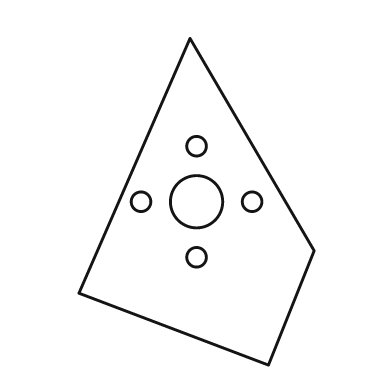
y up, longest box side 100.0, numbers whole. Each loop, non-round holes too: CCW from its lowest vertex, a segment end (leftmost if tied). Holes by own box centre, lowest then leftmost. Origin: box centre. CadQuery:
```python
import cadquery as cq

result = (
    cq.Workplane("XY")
    .moveTo(22.0, -50.0)
    .lineTo(36.0, -15.0)
    .lineTo(-2.0, 50.0)
    .lineTo(-36.0, -28.0)
    .close()
    .moveTo(0.0, -17.0)
    .circle(3.0)
    .moveTo(-17.0, 0.0)
    .circle(3.0)
    .moveTo(0.0, 0.0)
    .circle(8.0)
    .moveTo(17.0, 0.0)
    .circle(3.0)
    .moveTo(0.0, 17.0)
    .circle(3.0)
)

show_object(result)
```